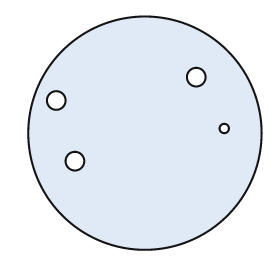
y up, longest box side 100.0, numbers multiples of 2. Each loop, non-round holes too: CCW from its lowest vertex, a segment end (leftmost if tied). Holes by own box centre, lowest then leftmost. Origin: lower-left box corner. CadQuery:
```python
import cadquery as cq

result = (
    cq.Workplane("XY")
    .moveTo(50.0, 50.0)
    .circle(50.0)
    .moveTo(20.0, 38.0)
    .circle(4.0)
    .moveTo(84.0, 52.0)
    .circle(2.0)
    .moveTo(12.0, 64.0)
    .circle(4.0)
    .moveTo(72.0, 74.0)
    .circle(4.0)
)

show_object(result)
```